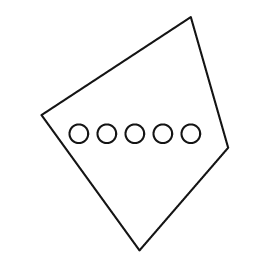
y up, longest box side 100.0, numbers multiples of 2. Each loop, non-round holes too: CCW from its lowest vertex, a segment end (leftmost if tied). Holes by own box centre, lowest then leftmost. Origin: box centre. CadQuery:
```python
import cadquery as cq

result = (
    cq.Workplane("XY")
    .moveTo(2.0, -50.0)
    .lineTo(40.0, -6.0)
    .lineTo(24.0, 50.0)
    .lineTo(-40.0, 8.0)
    .close()
    .moveTo(-24.0, 0.0)
    .circle(4.0)
    .moveTo(-12.0, 0.0)
    .circle(4.0)
    .moveTo(0.0, 0.0)
    .circle(4.0)
    .moveTo(12.0, 0.0)
    .circle(4.0)
    .moveTo(24.0, 0.0)
    .circle(4.0)
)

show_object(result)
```